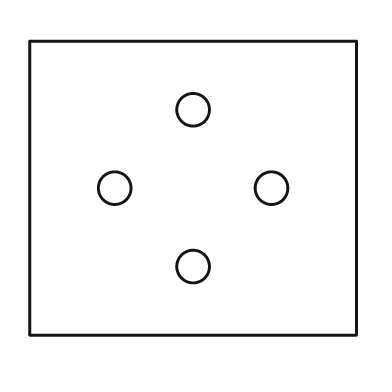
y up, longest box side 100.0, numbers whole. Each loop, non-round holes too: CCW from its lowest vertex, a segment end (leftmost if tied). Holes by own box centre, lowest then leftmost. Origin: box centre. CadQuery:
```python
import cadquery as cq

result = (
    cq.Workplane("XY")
    .moveTo(-50.0, -45.0)
    .lineTo(50.0, -45.0)
    .lineTo(50.0, 45.0)
    .lineTo(-50.0, 45.0)
    .close()
    .moveTo(0.0, -24.0)
    .circle(5.0)
    .moveTo(-24.0, 0.0)
    .circle(5.0)
    .moveTo(24.0, 0.0)
    .circle(5.0)
    .moveTo(0.0, 24.0)
    .circle(5.0)
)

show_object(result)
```